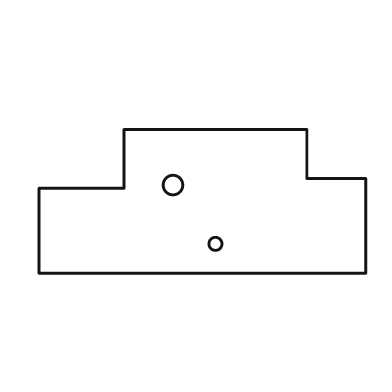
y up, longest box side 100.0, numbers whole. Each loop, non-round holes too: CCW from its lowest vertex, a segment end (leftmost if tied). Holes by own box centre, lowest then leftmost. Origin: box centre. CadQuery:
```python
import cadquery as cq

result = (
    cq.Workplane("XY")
    .moveTo(-50.0, -22.0)
    .lineTo(50.0, -22.0)
    .lineTo(50.0, 7.0)
    .lineTo(32.0, 7.0)
    .lineTo(32.0, 22.0)
    .lineTo(-24.0, 22.0)
    .lineTo(-24.0, 4.0)
    .lineTo(-50.0, 4.0)
    .close()
    .moveTo(4.0, -13.0)
    .circle(2.0)
    .moveTo(-9.0, 5.0)
    .circle(3.0)
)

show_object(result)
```